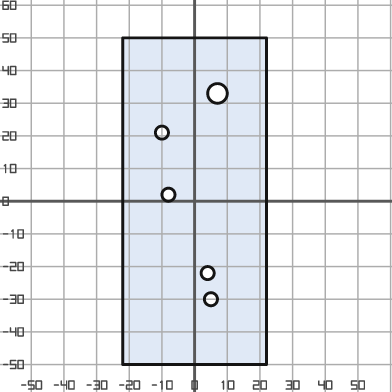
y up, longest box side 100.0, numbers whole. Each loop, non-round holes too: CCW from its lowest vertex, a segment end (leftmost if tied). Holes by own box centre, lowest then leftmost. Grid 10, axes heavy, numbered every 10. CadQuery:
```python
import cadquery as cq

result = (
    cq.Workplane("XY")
    .moveTo(-22.0, -50.0)
    .lineTo(22.0, -50.0)
    .lineTo(22.0, 50.0)
    .lineTo(-22.0, 50.0)
    .close()
    .moveTo(5.0, -30.0)
    .circle(2.0)
    .moveTo(4.0, -22.0)
    .circle(2.0)
    .moveTo(-8.0, 2.0)
    .circle(2.0)
    .moveTo(-10.0, 21.0)
    .circle(2.0)
    .moveTo(7.0, 33.0)
    .circle(3.0)
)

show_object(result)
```